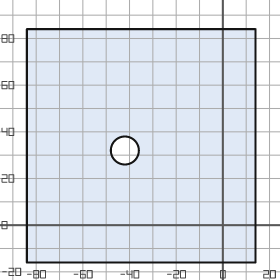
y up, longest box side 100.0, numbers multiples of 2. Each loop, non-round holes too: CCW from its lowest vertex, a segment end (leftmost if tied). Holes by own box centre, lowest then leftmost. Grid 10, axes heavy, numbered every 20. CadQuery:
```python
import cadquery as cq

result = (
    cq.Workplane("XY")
    .moveTo(-84.0, -16.0)
    .lineTo(14.0, -16.0)
    .lineTo(14.0, 84.0)
    .lineTo(-84.0, 84.0)
    .close()
    .moveTo(-42.0, 32.0)
    .circle(6.0)
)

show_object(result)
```